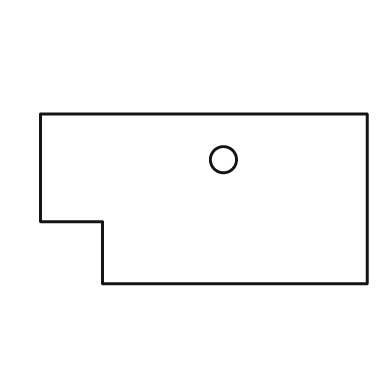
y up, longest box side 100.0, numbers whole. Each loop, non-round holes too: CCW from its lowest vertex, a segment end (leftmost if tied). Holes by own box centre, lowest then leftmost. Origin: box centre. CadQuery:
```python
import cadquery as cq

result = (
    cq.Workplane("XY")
    .moveTo(-31.0, -26.0)
    .lineTo(50.0, -26.0)
    .lineTo(50.0, 26.0)
    .lineTo(-50.0, 26.0)
    .lineTo(-50.0, -7.0)
    .lineTo(-31.0, -7.0)
    .close()
    .moveTo(6.0, 12.0)
    .circle(4.0)
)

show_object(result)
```